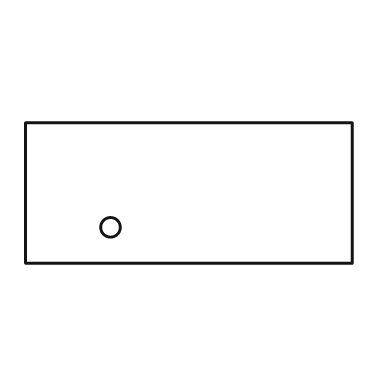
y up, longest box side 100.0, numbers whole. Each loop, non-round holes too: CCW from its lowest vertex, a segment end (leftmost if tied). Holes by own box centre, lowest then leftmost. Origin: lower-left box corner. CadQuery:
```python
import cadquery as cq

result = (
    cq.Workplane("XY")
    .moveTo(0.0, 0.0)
    .lineTo(100.0, 0.0)
    .lineTo(100.0, 43.0)
    .lineTo(0.0, 43.0)
    .close()
    .moveTo(26.0, 11.0)
    .circle(3.0)
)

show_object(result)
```